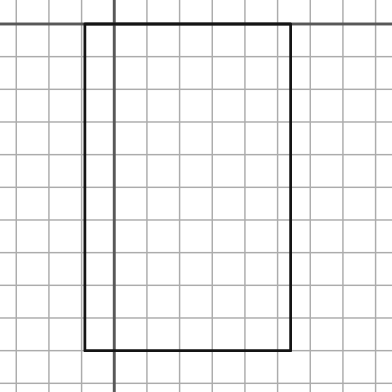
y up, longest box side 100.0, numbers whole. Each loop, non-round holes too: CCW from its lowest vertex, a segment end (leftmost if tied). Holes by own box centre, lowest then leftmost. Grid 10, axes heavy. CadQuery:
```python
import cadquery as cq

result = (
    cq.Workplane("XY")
    .moveTo(-9.0, -100.0)
    .lineTo(54.0, -100.0)
    .lineTo(54.0, 0.0)
    .lineTo(-9.0, 0.0)
    .close()
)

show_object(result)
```